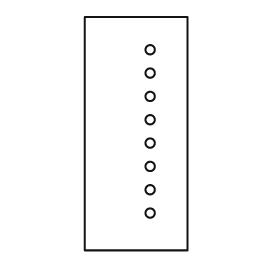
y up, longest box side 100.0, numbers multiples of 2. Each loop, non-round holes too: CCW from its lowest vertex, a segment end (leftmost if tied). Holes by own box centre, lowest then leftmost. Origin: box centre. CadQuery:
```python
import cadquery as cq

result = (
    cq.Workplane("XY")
    .moveTo(-22.0, -50.0)
    .lineTo(22.0, -50.0)
    .lineTo(22.0, 50.0)
    .lineTo(-22.0, 50.0)
    .close()
    .moveTo(6.0, -34.0)
    .circle(2.0)
    .moveTo(6.0, -24.0)
    .circle(2.0)
    .moveTo(6.0, -14.0)
    .circle(2.0)
    .moveTo(6.0, -4.0)
    .circle(2.0)
    .moveTo(6.0, 6.0)
    .circle(2.0)
    .moveTo(6.0, 16.0)
    .circle(2.0)
    .moveTo(6.0, 26.0)
    .circle(2.0)
    .moveTo(6.0, 36.0)
    .circle(2.0)
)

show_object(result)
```